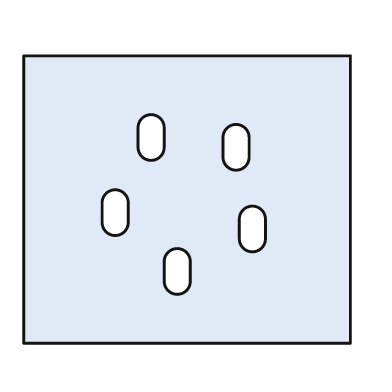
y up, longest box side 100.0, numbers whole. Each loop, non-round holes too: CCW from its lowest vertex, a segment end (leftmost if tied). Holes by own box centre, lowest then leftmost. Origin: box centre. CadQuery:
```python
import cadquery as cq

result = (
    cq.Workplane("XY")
    .moveTo(-50.0, -44.0)
    .lineTo(50.0, -44.0)
    .lineTo(50.0, 44.0)
    .lineTo(-50.0, 44.0)
    .close()
    .moveTo(-7.0, -25.0)
    .threePointArc((-3.0, -29.0), (1.0, -25.0))
    .lineTo(1.0, -19.0)
    .threePointArc((-3.0, -15.0), (-7.0, -19.0))
    .close()
    .moveTo(16.0, -12.0)
    .threePointArc((20.0, -16.0), (24.0, -12.0))
    .lineTo(24.0, -6.0)
    .threePointArc((20.0, -2.0), (16.0, -6.0))
    .close()
    .moveTo(-26.0, -7.0)
    .threePointArc((-22.0, -11.0), (-18.0, -7.0))
    .lineTo(-18.0, -1.0)
    .threePointArc((-22.0, 3.0), (-26.0, -1.0))
    .close()
    .moveTo(11.0, 13.0)
    .threePointArc((15.0, 9.0), (19.0, 13.0))
    .lineTo(19.0, 19.0)
    .threePointArc((15.0, 23.0), (11.0, 19.0))
    .close()
    .moveTo(-15.0, 16.0)
    .threePointArc((-11.0, 12.0), (-7.0, 16.0))
    .lineTo(-7.0, 22.0)
    .threePointArc((-11.0, 26.0), (-15.0, 22.0))
    .close()
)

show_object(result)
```